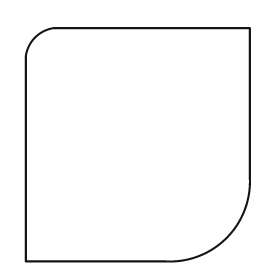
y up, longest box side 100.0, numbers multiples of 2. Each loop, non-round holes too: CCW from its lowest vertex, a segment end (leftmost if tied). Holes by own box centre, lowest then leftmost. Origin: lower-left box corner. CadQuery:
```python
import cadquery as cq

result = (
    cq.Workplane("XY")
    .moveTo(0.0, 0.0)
    .lineTo(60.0, 0.0)
    .threePointArc((86.0, 10.0), (96.0, 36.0))
    .lineTo(96.0, 100.0)
    .lineTo(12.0, 100.0)
    .threePointArc((4.0, 96.0), (0.0, 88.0))
    .close()
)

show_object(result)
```